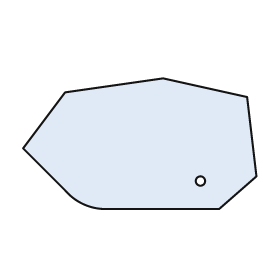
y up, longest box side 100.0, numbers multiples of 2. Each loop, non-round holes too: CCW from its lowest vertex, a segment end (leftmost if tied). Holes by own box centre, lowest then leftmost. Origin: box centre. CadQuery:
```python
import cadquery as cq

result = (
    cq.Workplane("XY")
    .moveTo(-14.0, -28.0)
    .lineTo(34.0, -28.0)
    .lineTo(50.0, -14.0)
    .lineTo(46.0, 20.0)
    .lineTo(10.0, 28.0)
    .lineTo(-32.0, 22.0)
    .lineTo(-50.0, -2.0)
    .lineTo(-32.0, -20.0)
    .threePointArc((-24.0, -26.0), (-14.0, -28.0))
    .close()
    .moveTo(26.0, -16.0)
    .circle(2.0)
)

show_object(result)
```